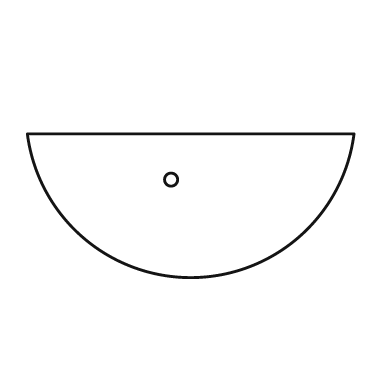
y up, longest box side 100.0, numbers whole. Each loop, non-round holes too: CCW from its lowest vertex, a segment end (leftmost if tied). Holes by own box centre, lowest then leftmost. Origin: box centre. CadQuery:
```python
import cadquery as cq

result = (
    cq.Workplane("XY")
    .moveTo(-50.0, 22.0)
    .threePointArc((0.0, -22.0), (50.0, 22.0))
    .close()
    .moveTo(-6.0, 8.0)
    .circle(2.0)
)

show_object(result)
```